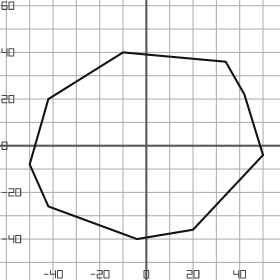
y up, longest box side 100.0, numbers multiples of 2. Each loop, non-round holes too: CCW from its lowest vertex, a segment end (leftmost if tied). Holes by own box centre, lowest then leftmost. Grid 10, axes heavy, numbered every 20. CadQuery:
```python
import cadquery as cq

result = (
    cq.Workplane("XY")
    .moveTo(-4.0, -40.0)
    .lineTo(20.0, -36.0)
    .lineTo(50.0, -4.0)
    .lineTo(42.0, 22.0)
    .lineTo(34.0, 36.0)
    .lineTo(-10.0, 40.0)
    .lineTo(-42.0, 20.0)
    .lineTo(-50.0, -8.0)
    .lineTo(-42.0, -26.0)
    .close()
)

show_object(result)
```